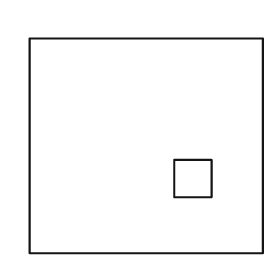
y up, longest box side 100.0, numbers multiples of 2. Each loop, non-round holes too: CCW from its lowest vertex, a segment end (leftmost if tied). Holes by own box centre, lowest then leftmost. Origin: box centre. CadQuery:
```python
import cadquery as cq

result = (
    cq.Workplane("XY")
    .moveTo(-50.0, -46.0)
    .lineTo(50.0, -46.0)
    .lineTo(50.0, 46.0)
    .lineTo(-50.0, 46.0)
    .close()
    .moveTo(12.0, -22.0)
    .lineTo(28.0, -22.0)
    .lineTo(28.0, -6.0)
    .lineTo(12.0, -6.0)
    .close()
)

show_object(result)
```